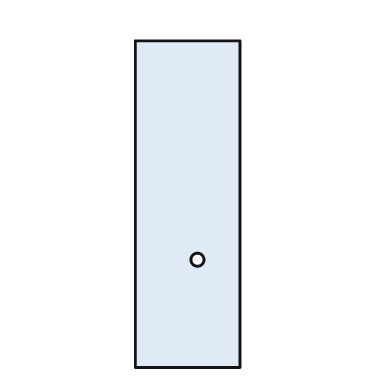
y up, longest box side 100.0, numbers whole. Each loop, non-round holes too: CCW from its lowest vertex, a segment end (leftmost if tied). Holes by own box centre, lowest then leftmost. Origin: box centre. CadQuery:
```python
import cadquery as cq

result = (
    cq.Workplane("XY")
    .moveTo(-16.0, -50.0)
    .lineTo(16.0, -50.0)
    .lineTo(16.0, 50.0)
    .lineTo(-16.0, 50.0)
    .close()
    .moveTo(3.0, -17.0)
    .circle(2.0)
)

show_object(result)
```